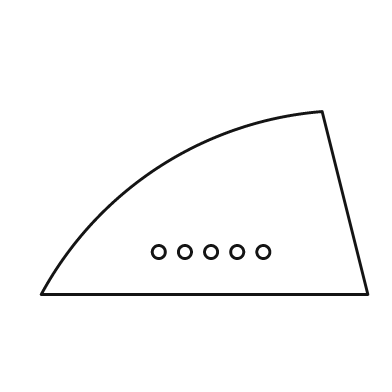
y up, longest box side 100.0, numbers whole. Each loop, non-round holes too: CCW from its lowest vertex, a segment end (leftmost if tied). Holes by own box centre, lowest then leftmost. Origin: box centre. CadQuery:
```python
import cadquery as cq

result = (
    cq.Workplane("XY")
    .moveTo(-50.0, -28.0)
    .lineTo(50.0, -28.0)
    .lineTo(36.0, 28.0)
    .threePointArc((-14.0, 11.0), (-50.0, -28.0))
    .close()
    .moveTo(-14.0, -15.0)
    .circle(2.0)
    .moveTo(-6.0, -15.0)
    .circle(2.0)
    .moveTo(2.0, -15.0)
    .circle(2.0)
    .moveTo(10.0, -15.0)
    .circle(2.0)
    .moveTo(18.0, -15.0)
    .circle(2.0)
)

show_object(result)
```